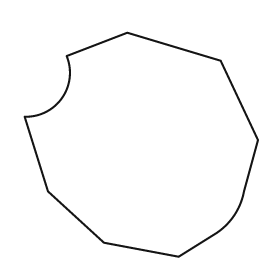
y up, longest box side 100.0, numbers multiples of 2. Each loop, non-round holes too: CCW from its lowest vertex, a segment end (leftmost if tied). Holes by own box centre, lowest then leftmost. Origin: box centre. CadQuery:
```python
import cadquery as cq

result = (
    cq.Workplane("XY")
    .moveTo(16.0, -48.0)
    .lineTo(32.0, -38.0)
    .threePointArc((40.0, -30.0), (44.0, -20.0))
    .lineTo(50.0, 2.0)
    .lineTo(34.0, 36.0)
    .lineTo(-6.0, 48.0)
    .lineTo(-32.0, 38.0)
    .threePointArc((-34.0, 20.0), (-50.0, 12.0))
    .lineTo(-40.0, -20.0)
    .lineTo(-16.0, -42.0)
    .close()
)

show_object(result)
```